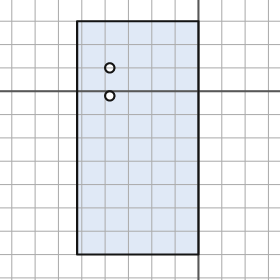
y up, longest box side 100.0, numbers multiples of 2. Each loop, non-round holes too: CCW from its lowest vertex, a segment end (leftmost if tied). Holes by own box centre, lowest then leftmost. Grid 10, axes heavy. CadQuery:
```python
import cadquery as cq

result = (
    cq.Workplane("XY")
    .moveTo(-52.0, -70.0)
    .lineTo(0.0, -70.0)
    .lineTo(0.0, 30.0)
    .lineTo(-52.0, 30.0)
    .close()
    .moveTo(-38.0, -2.0)
    .circle(2.0)
    .moveTo(-38.0, 10.0)
    .circle(2.0)
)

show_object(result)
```